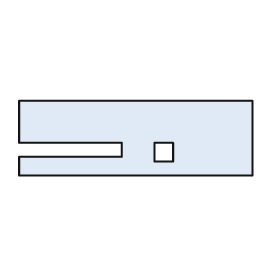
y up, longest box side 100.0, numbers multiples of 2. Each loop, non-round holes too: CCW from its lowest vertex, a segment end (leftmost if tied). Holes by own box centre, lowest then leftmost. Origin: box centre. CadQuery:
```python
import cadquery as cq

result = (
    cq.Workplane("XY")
    .moveTo(-50.0, -16.0)
    .lineTo(50.0, -16.0)
    .lineTo(50.0, 16.0)
    .lineTo(-50.0, 16.0)
    .lineTo(-50.0, -2.0)
    .lineTo(-6.0, -2.0)
    .lineTo(-6.0, -8.0)
    .lineTo(-50.0, -8.0)
    .close()
    .moveTo(8.0, -10.0)
    .lineTo(16.0, -10.0)
    .lineTo(16.0, -2.0)
    .lineTo(8.0, -2.0)
    .close()
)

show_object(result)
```